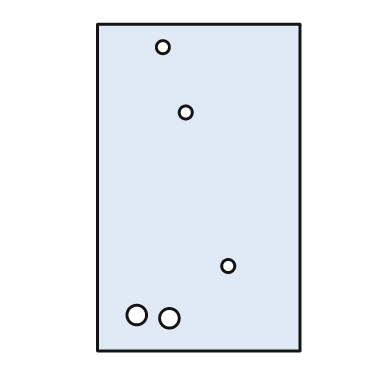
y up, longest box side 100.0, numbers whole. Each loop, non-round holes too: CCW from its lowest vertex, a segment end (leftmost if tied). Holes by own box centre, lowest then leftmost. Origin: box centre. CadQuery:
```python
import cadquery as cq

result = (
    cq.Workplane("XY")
    .moveTo(-31.0, -50.0)
    .lineTo(31.0, -50.0)
    .lineTo(31.0, 50.0)
    .lineTo(-31.0, 50.0)
    .close()
    .moveTo(-9.0, -40.0)
    .circle(3.0)
    .moveTo(-19.0, -39.0)
    .circle(3.0)
    .moveTo(9.0, -24.0)
    .circle(2.0)
    .moveTo(-4.0, 23.0)
    .circle(2.0)
    .moveTo(-11.0, 43.0)
    .circle(2.0)
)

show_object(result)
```